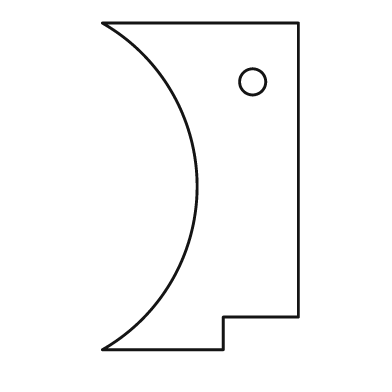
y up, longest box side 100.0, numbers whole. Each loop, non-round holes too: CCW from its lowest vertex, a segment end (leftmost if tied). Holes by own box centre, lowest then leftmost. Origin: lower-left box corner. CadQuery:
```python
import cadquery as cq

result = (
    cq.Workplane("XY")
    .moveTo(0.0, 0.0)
    .lineTo(37.0, 0.0)
    .lineTo(37.0, 10.0)
    .lineTo(60.0, 10.0)
    .lineTo(60.0, 100.0)
    .lineTo(0.0, 100.0)
    .threePointArc((29.0, 50.0), (0.0, 0.0))
    .close()
    .moveTo(46.0, 82.0)
    .circle(4.0)
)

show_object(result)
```